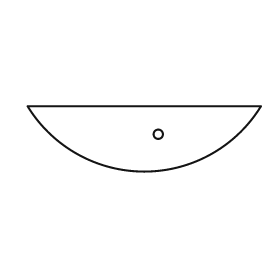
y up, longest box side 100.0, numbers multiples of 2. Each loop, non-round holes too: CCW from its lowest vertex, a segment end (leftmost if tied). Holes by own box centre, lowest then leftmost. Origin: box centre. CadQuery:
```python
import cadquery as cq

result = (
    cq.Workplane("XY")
    .moveTo(-50.0, 14.0)
    .threePointArc((0.0, -14.0), (50.0, 14.0))
    .close()
    .moveTo(6.0, 2.0)
    .circle(2.0)
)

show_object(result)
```